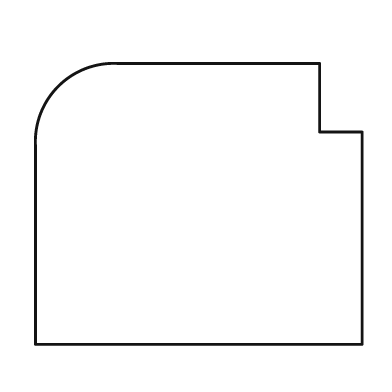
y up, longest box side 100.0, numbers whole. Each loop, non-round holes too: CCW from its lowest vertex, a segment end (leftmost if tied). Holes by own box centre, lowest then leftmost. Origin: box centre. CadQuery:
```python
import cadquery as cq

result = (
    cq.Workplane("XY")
    .moveTo(-50.0, -43.0)
    .lineTo(50.0, -43.0)
    .lineTo(50.0, 22.0)
    .lineTo(37.0, 22.0)
    .lineTo(37.0, 43.0)
    .lineTo(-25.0, 43.0)
    .threePointArc((-43.0, 36.0), (-50.0, 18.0))
    .close()
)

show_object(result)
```